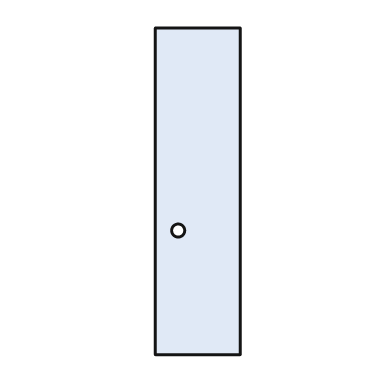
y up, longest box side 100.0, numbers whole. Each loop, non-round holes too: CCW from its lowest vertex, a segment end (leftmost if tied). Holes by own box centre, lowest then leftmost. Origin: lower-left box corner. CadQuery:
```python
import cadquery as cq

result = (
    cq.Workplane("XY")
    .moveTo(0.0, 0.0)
    .lineTo(26.0, 0.0)
    .lineTo(26.0, 100.0)
    .lineTo(0.0, 100.0)
    .close()
    .moveTo(7.0, 38.0)
    .circle(2.0)
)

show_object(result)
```